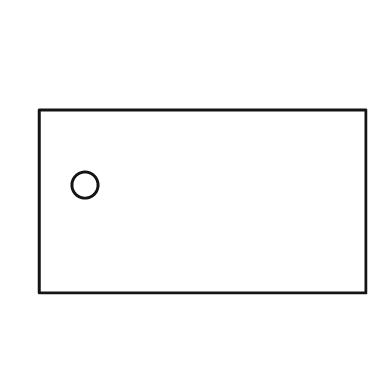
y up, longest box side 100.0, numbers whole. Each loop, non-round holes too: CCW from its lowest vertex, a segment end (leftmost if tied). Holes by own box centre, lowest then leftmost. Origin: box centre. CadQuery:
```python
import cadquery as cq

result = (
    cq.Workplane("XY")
    .moveTo(-50.0, -28.0)
    .lineTo(50.0, -28.0)
    .lineTo(50.0, 28.0)
    .lineTo(-50.0, 28.0)
    .close()
    .moveTo(-36.0, 5.0)
    .circle(4.0)
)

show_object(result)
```